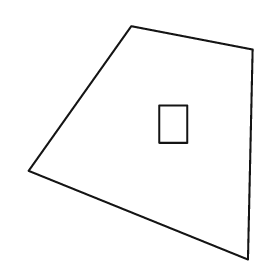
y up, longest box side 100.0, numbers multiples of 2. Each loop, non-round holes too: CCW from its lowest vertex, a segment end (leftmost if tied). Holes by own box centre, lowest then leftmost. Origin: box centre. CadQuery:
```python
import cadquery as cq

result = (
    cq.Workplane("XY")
    .moveTo(46.0, -50.0)
    .lineTo(48.0, 40.0)
    .lineTo(-4.0, 50.0)
    .lineTo(-48.0, -12.0)
    .close()
    .moveTo(8.0, 0.0)
    .lineTo(20.0, 0.0)
    .lineTo(20.0, 16.0)
    .lineTo(8.0, 16.0)
    .close()
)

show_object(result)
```